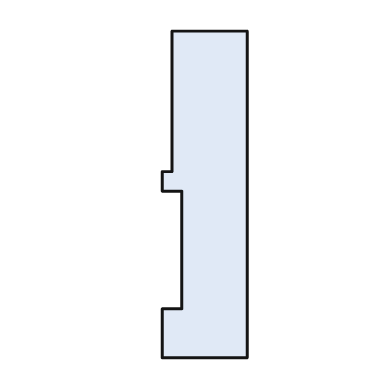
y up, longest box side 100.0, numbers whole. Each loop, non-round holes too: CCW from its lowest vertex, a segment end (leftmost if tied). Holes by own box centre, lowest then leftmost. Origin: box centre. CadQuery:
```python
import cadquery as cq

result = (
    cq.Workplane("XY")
    .moveTo(-13.0, -50.0)
    .lineTo(13.0, -50.0)
    .lineTo(13.0, 50.0)
    .lineTo(-10.0, 50.0)
    .lineTo(-10.0, 7.0)
    .lineTo(-13.0, 7.0)
    .lineTo(-13.0, 1.0)
    .lineTo(-7.0, 1.0)
    .lineTo(-7.0, -35.0)
    .lineTo(-13.0, -35.0)
    .close()
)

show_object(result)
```